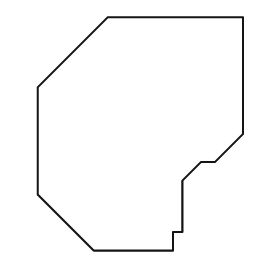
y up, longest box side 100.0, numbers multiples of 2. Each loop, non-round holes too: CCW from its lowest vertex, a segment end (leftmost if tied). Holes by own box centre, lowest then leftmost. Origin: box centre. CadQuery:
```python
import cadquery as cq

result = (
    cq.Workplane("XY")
    .moveTo(-20.0, -50.0)
    .lineTo(14.0, -50.0)
    .lineTo(14.0, -42.0)
    .lineTo(18.0, -42.0)
    .lineTo(18.0, -20.0)
    .lineTo(26.0, -12.0)
    .lineTo(32.0, -12.0)
    .lineTo(44.0, 0.0)
    .lineTo(44.0, 50.0)
    .lineTo(-14.0, 50.0)
    .lineTo(-44.0, 20.0)
    .lineTo(-44.0, -26.0)
    .close()
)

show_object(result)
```